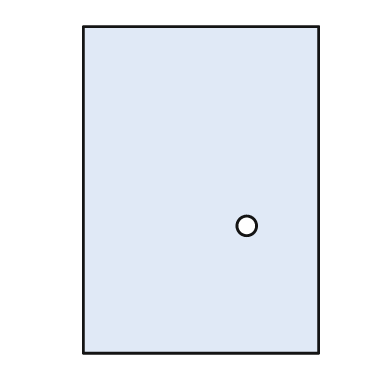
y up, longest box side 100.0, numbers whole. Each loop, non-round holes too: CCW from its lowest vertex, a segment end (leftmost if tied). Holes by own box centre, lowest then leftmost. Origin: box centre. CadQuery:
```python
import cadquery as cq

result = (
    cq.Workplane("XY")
    .moveTo(-36.0, -50.0)
    .lineTo(36.0, -50.0)
    .lineTo(36.0, 50.0)
    .lineTo(-36.0, 50.0)
    .close()
    .moveTo(14.0, -11.0)
    .circle(3.0)
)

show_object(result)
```